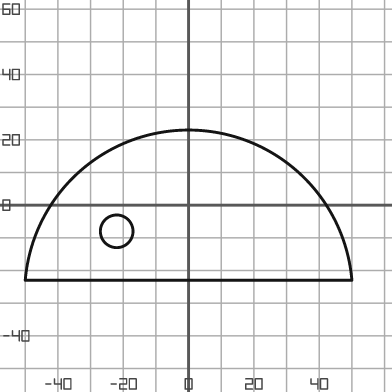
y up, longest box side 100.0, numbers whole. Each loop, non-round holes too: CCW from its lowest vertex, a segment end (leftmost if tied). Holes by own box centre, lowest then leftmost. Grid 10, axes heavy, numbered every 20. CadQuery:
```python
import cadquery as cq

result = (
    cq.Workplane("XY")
    .moveTo(-50.0, -23.0)
    .lineTo(50.0, -23.0)
    .threePointArc((0.0, 23.0), (-50.0, -23.0))
    .close()
    .moveTo(-22.0, -8.0)
    .circle(5.0)
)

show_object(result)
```